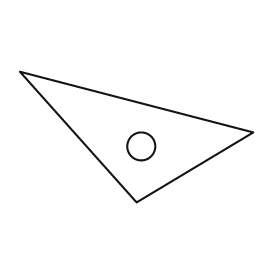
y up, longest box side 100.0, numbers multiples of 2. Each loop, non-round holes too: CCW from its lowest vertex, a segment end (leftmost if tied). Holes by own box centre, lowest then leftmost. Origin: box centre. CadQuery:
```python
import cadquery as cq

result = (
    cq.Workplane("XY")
    .moveTo(0.0, -28.0)
    .lineTo(50.0, 2.0)
    .lineTo(-50.0, 28.0)
    .close()
    .moveTo(2.0, -4.0)
    .circle(6.0)
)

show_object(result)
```